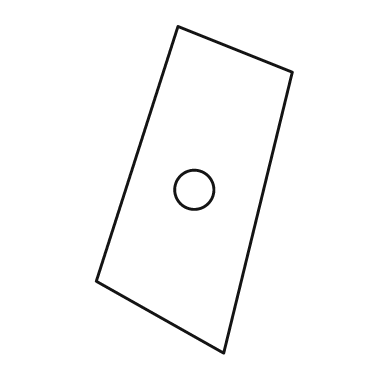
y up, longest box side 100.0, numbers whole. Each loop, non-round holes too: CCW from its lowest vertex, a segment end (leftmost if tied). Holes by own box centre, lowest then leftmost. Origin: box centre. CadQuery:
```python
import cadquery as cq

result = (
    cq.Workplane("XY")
    .moveTo(9.0, -50.0)
    .lineTo(30.0, 36.0)
    .lineTo(-5.0, 50.0)
    .lineTo(-30.0, -28.0)
    .close()
    .moveTo(0.0, 0.0)
    .circle(6.0)
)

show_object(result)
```